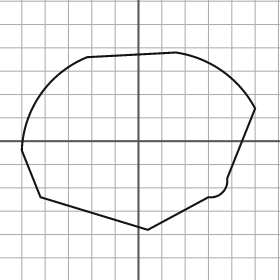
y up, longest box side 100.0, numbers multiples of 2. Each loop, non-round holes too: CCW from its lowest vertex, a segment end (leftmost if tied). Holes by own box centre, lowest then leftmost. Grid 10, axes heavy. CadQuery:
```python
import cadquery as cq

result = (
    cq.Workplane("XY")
    .moveTo(4.0, -38.0)
    .lineTo(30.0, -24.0)
    .threePointArc((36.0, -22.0), (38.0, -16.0))
    .lineTo(50.0, 14.0)
    .threePointArc((36.0, 30.0), (16.0, 38.0))
    .lineTo(-22.0, 36.0)
    .threePointArc((-42.0, 20.0), (-50.0, -4.0))
    .lineTo(-42.0, -24.0)
    .close()
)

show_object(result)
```